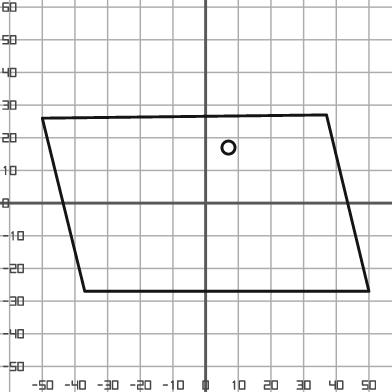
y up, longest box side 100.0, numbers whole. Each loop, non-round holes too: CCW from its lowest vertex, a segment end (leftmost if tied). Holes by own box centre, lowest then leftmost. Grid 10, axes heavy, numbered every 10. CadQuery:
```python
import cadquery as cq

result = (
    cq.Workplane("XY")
    .moveTo(-37.0, -27.0)
    .lineTo(50.0, -27.0)
    .lineTo(37.0, 27.0)
    .lineTo(-50.0, 26.0)
    .close()
    .moveTo(7.0, 17.0)
    .circle(2.0)
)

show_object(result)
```